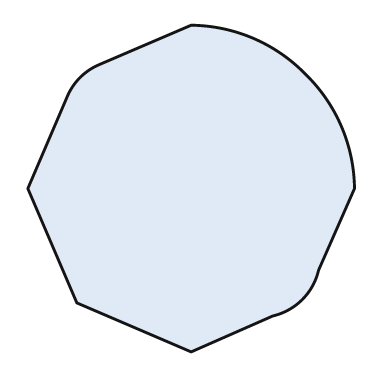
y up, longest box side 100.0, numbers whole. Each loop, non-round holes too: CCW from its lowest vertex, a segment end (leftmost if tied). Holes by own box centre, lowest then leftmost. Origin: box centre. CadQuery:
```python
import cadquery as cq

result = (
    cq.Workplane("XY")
    .moveTo(0.0, -50.0)
    .lineTo(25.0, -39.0)
    .threePointArc((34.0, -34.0), (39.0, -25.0))
    .lineTo(50.0, 0.0)
    .threePointArc((46.0, 19.0), (35.0, 35.0))
    .threePointArc((19.0, 46.0), (0.0, 50.0))
    .lineTo(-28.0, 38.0)
    .threePointArc((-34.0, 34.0), (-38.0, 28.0))
    .lineTo(-50.0, 0.0)
    .lineTo(-35.0, -35.0)
    .close()
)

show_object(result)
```